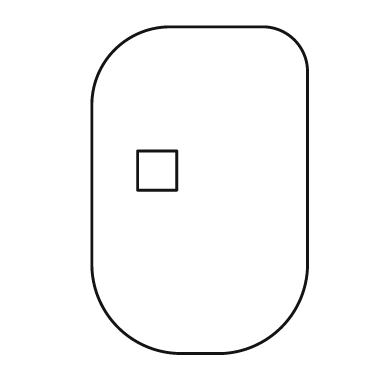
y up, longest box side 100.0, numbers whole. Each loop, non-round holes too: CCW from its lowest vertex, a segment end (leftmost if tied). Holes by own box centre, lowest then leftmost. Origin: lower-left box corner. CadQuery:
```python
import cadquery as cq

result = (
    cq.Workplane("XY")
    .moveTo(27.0, 0.0)
    .lineTo(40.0, 0.0)
    .threePointArc((58.0, 8.0), (66.0, 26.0))
    .lineTo(66.0, 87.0)
    .threePointArc((62.0, 96.0), (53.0, 100.0))
    .lineTo(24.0, 100.0)
    .threePointArc((7.0, 93.0), (0.0, 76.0))
    .lineTo(0.0, 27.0)
    .threePointArc((8.0, 8.0), (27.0, 0.0))
    .close()
    .moveTo(14.0, 50.0)
    .lineTo(26.0, 50.0)
    .lineTo(26.0, 62.0)
    .lineTo(14.0, 62.0)
    .close()
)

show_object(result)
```